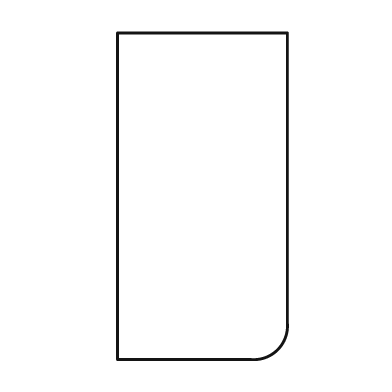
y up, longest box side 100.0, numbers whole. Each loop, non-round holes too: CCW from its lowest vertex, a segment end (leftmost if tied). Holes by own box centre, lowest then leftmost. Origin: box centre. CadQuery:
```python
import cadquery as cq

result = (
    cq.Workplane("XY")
    .moveTo(-26.0, -50.0)
    .lineTo(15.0, -50.0)
    .threePointArc((23.0, -47.0), (26.0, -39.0))
    .lineTo(26.0, 50.0)
    .lineTo(-26.0, 50.0)
    .close()
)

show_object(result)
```